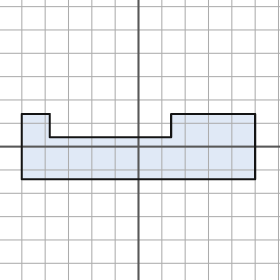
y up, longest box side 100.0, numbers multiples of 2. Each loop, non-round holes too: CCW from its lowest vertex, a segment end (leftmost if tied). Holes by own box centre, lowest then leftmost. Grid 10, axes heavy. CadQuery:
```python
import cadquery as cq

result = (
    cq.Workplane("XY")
    .moveTo(-50.0, -14.0)
    .lineTo(50.0, -14.0)
    .lineTo(50.0, 14.0)
    .lineTo(14.0, 14.0)
    .lineTo(14.0, 4.0)
    .lineTo(-38.0, 4.0)
    .lineTo(-38.0, 14.0)
    .lineTo(-50.0, 14.0)
    .close()
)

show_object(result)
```